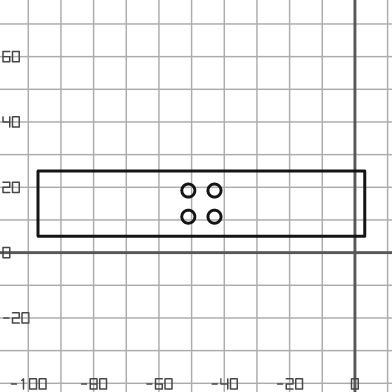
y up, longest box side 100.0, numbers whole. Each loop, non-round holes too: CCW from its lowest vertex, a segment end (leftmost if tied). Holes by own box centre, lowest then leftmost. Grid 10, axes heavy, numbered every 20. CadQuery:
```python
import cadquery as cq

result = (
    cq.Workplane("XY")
    .moveTo(-97.0, 5.0)
    .lineTo(3.0, 5.0)
    .lineTo(3.0, 25.0)
    .lineTo(-97.0, 25.0)
    .close()
    .moveTo(-51.0, 11.0)
    .circle(2.0)
    .moveTo(-43.0, 11.0)
    .circle(2.0)
    .moveTo(-51.0, 19.0)
    .circle(2.0)
    .moveTo(-43.0, 19.0)
    .circle(2.0)
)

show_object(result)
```